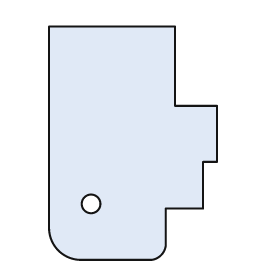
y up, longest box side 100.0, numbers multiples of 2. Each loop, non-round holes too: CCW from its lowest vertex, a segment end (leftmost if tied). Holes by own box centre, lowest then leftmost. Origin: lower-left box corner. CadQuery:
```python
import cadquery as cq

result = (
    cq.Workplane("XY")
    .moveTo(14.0, 0.0)
    .lineTo(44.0, 0.0)
    .threePointArc((48.0, 2.0), (50.0, 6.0))
    .lineTo(50.0, 22.0)
    .lineTo(66.0, 22.0)
    .lineTo(66.0, 42.0)
    .lineTo(72.0, 42.0)
    .lineTo(72.0, 66.0)
    .lineTo(54.0, 66.0)
    .lineTo(54.0, 100.0)
    .lineTo(0.0, 100.0)
    .lineTo(0.0, 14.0)
    .threePointArc((4.0, 4.0), (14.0, 0.0))
    .close()
    .moveTo(18.0, 24.0)
    .circle(4.0)
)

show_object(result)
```